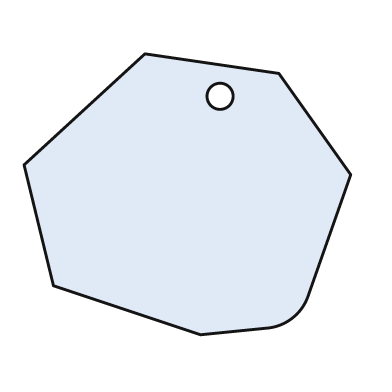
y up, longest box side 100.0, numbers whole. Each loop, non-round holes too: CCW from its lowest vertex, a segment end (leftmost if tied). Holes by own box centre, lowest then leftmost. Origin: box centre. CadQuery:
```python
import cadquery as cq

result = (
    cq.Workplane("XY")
    .moveTo(4.0, -43.0)
    .lineTo(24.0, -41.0)
    .threePointArc((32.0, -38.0), (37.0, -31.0))
    .lineTo(50.0, 6.0)
    .lineTo(28.0, 37.0)
    .lineTo(-13.0, 43.0)
    .lineTo(-50.0, 9.0)
    .lineTo(-41.0, -28.0)
    .close()
    .moveTo(10.0, 30.0)
    .circle(4.0)
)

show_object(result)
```